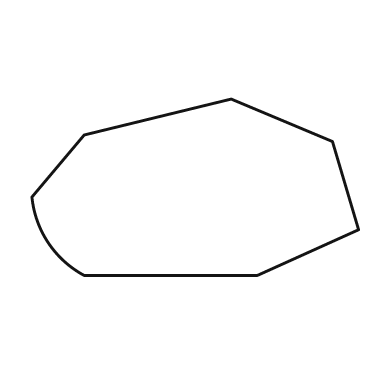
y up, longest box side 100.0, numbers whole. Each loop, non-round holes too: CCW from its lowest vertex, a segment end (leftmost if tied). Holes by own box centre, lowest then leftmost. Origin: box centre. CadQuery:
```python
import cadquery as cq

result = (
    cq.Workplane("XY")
    .moveTo(-34.0, -27.0)
    .lineTo(19.0, -27.0)
    .lineTo(50.0, -13.0)
    .lineTo(42.0, 14.0)
    .lineTo(11.0, 27.0)
    .lineTo(-34.0, 16.0)
    .lineTo(-50.0, -3.0)
    .threePointArc((-45.0, -17.0), (-34.0, -27.0))
    .close()
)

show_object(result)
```